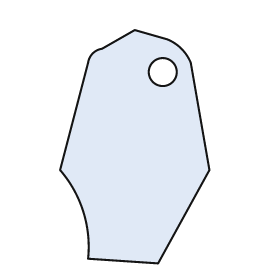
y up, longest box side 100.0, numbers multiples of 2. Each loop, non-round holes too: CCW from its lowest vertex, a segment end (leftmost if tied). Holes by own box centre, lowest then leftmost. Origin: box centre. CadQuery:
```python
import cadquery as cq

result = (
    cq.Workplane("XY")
    .moveTo(10.0, -50.0)
    .lineTo(32.0, -10.0)
    .lineTo(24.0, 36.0)
    .threePointArc((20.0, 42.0), (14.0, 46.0))
    .lineTo(0.0, 50.0)
    .lineTo(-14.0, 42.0)
    .threePointArc((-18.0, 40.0), (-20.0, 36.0))
    .lineTo(-32.0, -10.0)
    .threePointArc((-22.0, -28.0), (-20.0, -48.0))
    .close()
    .moveTo(12.0, 32.0)
    .circle(6.0)
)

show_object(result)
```